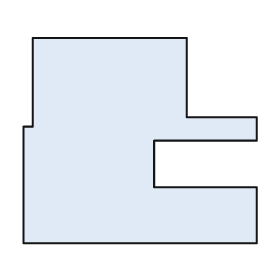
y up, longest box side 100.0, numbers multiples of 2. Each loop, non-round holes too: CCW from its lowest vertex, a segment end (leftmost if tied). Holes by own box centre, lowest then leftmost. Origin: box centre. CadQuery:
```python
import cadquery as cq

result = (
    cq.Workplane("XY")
    .moveTo(-50.0, -44.0)
    .lineTo(50.0, -44.0)
    .lineTo(50.0, -20.0)
    .lineTo(6.0, -20.0)
    .lineTo(6.0, 0.0)
    .lineTo(50.0, 0.0)
    .lineTo(50.0, 10.0)
    .lineTo(20.0, 10.0)
    .lineTo(20.0, 44.0)
    .lineTo(-46.0, 44.0)
    .lineTo(-46.0, 6.0)
    .lineTo(-50.0, 6.0)
    .close()
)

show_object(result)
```